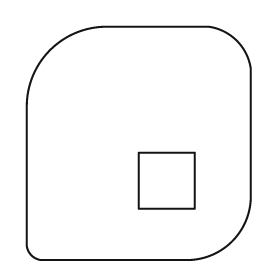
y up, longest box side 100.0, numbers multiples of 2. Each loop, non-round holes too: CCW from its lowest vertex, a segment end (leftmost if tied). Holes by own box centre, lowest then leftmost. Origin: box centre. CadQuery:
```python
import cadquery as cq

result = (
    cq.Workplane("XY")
    .moveTo(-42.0, -50.0)
    .lineTo(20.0, -50.0)
    .threePointArc((40.0, -42.0), (48.0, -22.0))
    .lineTo(48.0, 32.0)
    .threePointArc((42.0, 44.0), (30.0, 50.0))
    .lineTo(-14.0, 50.0)
    .threePointArc((-38.0, 40.0), (-48.0, 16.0))
    .lineTo(-48.0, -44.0)
    .threePointArc((-46.0, -48.0), (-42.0, -50.0))
    .close()
    .moveTo(0.0, -28.0)
    .lineTo(24.0, -28.0)
    .lineTo(24.0, -4.0)
    .lineTo(0.0, -4.0)
    .close()
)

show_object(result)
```